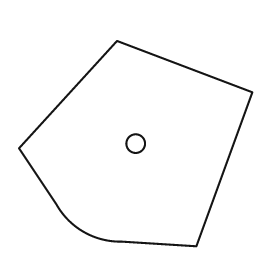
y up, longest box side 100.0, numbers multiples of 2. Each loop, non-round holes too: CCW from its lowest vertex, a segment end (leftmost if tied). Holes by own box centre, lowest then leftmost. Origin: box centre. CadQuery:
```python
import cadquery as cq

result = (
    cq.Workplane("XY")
    .moveTo(26.0, -44.0)
    .lineTo(50.0, 22.0)
    .lineTo(-8.0, 44.0)
    .lineTo(-50.0, -2.0)
    .lineTo(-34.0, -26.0)
    .threePointArc((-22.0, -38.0), (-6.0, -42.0))
    .close()
    .moveTo(0.0, 0.0)
    .circle(4.0)
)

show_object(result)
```